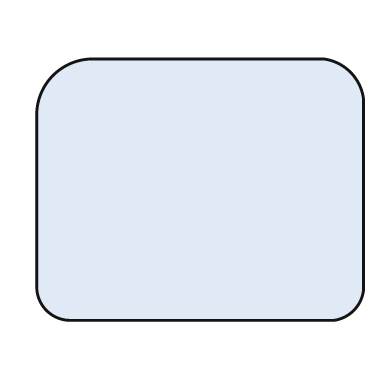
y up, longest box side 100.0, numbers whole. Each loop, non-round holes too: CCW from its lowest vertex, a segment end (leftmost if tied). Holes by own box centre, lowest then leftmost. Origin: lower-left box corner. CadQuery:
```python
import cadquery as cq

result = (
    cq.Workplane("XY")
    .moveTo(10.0, 0.0)
    .lineTo(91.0, 0.0)
    .threePointArc((97.0, 3.0), (100.0, 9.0))
    .lineTo(100.0, 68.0)
    .threePointArc((96.0, 76.0), (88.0, 80.0))
    .lineTo(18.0, 80.0)
    .threePointArc((5.0, 75.0), (0.0, 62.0))
    .lineTo(0.0, 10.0)
    .threePointArc((3.0, 3.0), (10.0, 0.0))
    .close()
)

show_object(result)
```